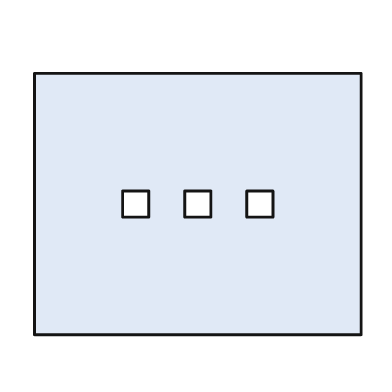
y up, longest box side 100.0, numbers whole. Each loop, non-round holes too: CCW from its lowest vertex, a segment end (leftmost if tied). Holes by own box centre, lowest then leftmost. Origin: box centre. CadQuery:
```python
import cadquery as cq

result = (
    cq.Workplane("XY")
    .moveTo(-50.0, -40.0)
    .lineTo(50.0, -40.0)
    .lineTo(50.0, 40.0)
    .lineTo(-50.0, 40.0)
    .close()
    .moveTo(-23.0, -4.0)
    .lineTo(-15.0, -4.0)
    .lineTo(-15.0, 4.0)
    .lineTo(-23.0, 4.0)
    .close()
    .moveTo(-4.0, -4.0)
    .lineTo(4.0, -4.0)
    .lineTo(4.0, 4.0)
    .lineTo(-4.0, 4.0)
    .close()
    .moveTo(15.0, -4.0)
    .lineTo(23.0, -4.0)
    .lineTo(23.0, 4.0)
    .lineTo(15.0, 4.0)
    .close()
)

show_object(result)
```